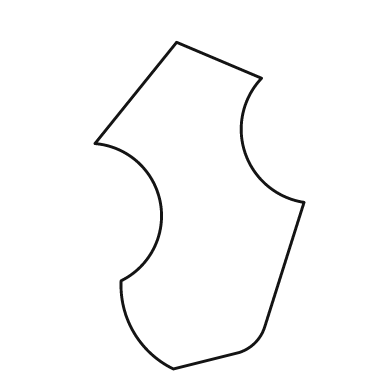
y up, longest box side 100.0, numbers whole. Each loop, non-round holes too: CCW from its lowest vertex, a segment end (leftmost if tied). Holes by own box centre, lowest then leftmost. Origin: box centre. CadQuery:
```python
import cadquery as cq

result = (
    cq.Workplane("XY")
    .moveTo(-8.0, -50.0)
    .lineTo(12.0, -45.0)
    .threePointArc((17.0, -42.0), (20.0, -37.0))
    .lineTo(32.0, 1.0)
    .threePointArc((14.0, 16.0), (19.0, 39.0))
    .lineTo(-7.0, 50.0)
    .lineTo(-32.0, 19.0)
    .threePointArc((-12.0, 1.0), (-24.0, -23.0))
    .threePointArc((-20.0, -39.0), (-8.0, -50.0))
    .close()
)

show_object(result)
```